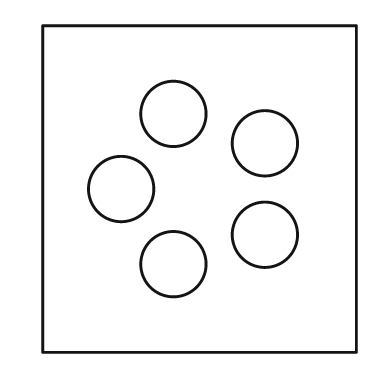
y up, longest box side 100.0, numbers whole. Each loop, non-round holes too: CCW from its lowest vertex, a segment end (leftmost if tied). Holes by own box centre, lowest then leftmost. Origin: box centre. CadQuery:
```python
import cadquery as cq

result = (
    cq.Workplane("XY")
    .moveTo(-48.0, -50.0)
    .lineTo(48.0, -50.0)
    .lineTo(48.0, 50.0)
    .lineTo(-48.0, 50.0)
    .close()
    .moveTo(-8.0, -23.0)
    .circle(10.0)
    .moveTo(20.0, -14.0)
    .circle(10.0)
    .moveTo(-24.0, 0.0)
    .circle(10.0)
    .moveTo(20.0, 14.0)
    .circle(10.0)
    .moveTo(-8.0, 23.0)
    .circle(10.0)
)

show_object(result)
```